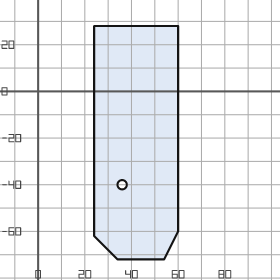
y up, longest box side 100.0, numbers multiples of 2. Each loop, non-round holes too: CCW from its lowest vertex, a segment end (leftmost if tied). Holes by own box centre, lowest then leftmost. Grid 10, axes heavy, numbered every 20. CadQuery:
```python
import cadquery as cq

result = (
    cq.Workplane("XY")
    .moveTo(34.0, -72.0)
    .lineTo(54.0, -72.0)
    .lineTo(60.0, -60.0)
    .lineTo(60.0, 28.0)
    .lineTo(24.0, 28.0)
    .lineTo(24.0, -62.0)
    .close()
    .moveTo(36.0, -40.0)
    .circle(2.0)
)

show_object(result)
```